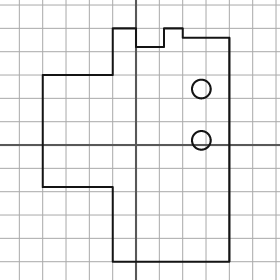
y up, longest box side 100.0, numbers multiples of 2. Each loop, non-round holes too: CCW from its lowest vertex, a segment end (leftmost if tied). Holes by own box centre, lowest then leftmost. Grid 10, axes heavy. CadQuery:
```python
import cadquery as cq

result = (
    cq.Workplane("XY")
    .moveTo(-10.0, -50.0)
    .lineTo(40.0, -50.0)
    .lineTo(40.0, 46.0)
    .lineTo(20.0, 46.0)
    .lineTo(20.0, 50.0)
    .lineTo(12.0, 50.0)
    .lineTo(12.0, 42.0)
    .lineTo(0.0, 42.0)
    .lineTo(0.0, 50.0)
    .lineTo(-10.0, 50.0)
    .lineTo(-10.0, 30.0)
    .lineTo(-40.0, 30.0)
    .lineTo(-40.0, -18.0)
    .lineTo(-10.0, -18.0)
    .close()
    .moveTo(28.0, 2.0)
    .circle(4.0)
    .moveTo(28.0, 24.0)
    .circle(4.0)
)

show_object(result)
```